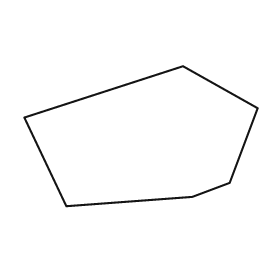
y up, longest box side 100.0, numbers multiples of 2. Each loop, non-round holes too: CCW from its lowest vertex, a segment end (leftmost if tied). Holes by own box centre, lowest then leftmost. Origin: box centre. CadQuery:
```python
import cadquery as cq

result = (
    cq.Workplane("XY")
    .moveTo(-32.0, -30.0)
    .lineTo(22.0, -26.0)
    .lineTo(38.0, -20.0)
    .lineTo(50.0, 12.0)
    .lineTo(18.0, 30.0)
    .lineTo(-50.0, 8.0)
    .close()
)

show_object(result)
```